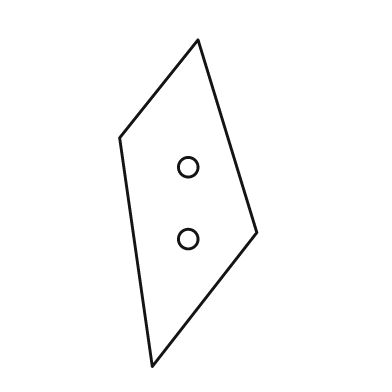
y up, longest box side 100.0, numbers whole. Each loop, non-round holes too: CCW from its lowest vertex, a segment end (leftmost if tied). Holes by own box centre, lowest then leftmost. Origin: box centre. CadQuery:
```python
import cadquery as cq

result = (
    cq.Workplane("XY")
    .moveTo(-11.0, -50.0)
    .lineTo(21.0, -9.0)
    .lineTo(3.0, 50.0)
    .lineTo(-21.0, 20.0)
    .close()
    .moveTo(0.0, -11.0)
    .circle(3.0)
    .moveTo(0.0, 11.0)
    .circle(3.0)
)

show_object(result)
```